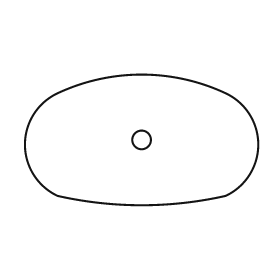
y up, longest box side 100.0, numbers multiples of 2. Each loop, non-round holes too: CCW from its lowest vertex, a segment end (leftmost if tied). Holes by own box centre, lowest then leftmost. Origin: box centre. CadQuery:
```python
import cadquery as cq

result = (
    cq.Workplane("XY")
    .moveTo(-36.0, -24.0)
    .threePointArc((0.0, -28.0), (36.0, -24.0))
    .threePointArc((50.0, -2.0), (36.0, 20.0))
    .threePointArc((0.0, 28.0), (-36.0, 20.0))
    .threePointArc((-50.0, -2.0), (-36.0, -24.0))
    .close()
    .moveTo(0.0, 0.0)
    .circle(4.0)
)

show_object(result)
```